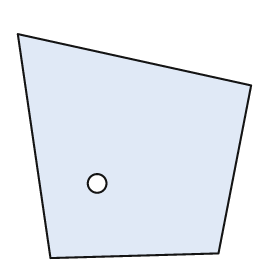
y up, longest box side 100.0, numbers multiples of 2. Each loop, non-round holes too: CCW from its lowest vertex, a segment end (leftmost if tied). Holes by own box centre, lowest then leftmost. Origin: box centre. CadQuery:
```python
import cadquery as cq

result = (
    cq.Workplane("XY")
    .moveTo(-36.0, -48.0)
    .lineTo(36.0, -46.0)
    .lineTo(50.0, 26.0)
    .lineTo(-50.0, 48.0)
    .close()
    .moveTo(-16.0, -16.0)
    .circle(4.0)
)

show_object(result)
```